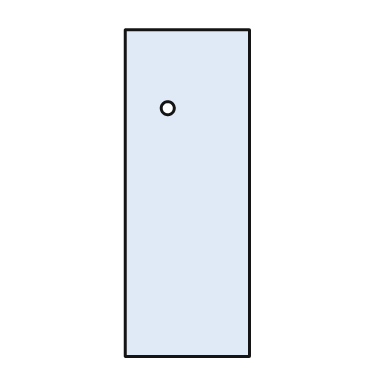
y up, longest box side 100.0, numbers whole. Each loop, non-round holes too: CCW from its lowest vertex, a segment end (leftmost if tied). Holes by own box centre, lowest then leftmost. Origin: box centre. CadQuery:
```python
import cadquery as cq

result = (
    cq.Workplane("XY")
    .moveTo(-19.0, -50.0)
    .lineTo(19.0, -50.0)
    .lineTo(19.0, 50.0)
    .lineTo(-19.0, 50.0)
    .close()
    .moveTo(-6.0, 26.0)
    .circle(2.0)
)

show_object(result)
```